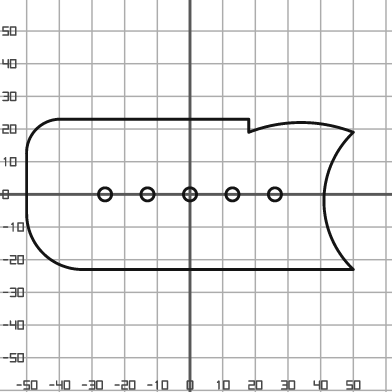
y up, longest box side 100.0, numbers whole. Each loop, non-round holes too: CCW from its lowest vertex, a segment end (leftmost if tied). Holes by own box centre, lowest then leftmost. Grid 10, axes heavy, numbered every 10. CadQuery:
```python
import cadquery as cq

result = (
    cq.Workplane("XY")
    .moveTo(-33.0, -23.0)
    .lineTo(50.0, -23.0)
    .threePointArc((41.0, -2.0), (50.0, 19.0))
    .threePointArc((34.0, 22.0), (18.0, 19.0))
    .lineTo(18.0, 23.0)
    .lineTo(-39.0, 23.0)
    .threePointArc((-47.0, 20.0), (-50.0, 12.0))
    .lineTo(-50.0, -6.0)
    .threePointArc((-45.0, -18.0), (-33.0, -23.0))
    .close()
    .moveTo(-26.0, 0.0)
    .circle(2.0)
    .moveTo(-13.0, 0.0)
    .circle(2.0)
    .moveTo(0.0, 0.0)
    .circle(2.0)
    .moveTo(13.0, 0.0)
    .circle(2.0)
    .moveTo(26.0, 0.0)
    .circle(2.0)
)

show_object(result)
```